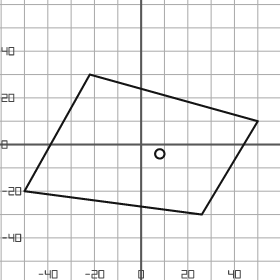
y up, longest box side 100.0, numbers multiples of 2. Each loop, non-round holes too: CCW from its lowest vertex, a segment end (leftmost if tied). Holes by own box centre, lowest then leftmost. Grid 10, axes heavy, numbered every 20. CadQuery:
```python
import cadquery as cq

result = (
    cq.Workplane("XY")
    .moveTo(26.0, -30.0)
    .lineTo(50.0, 10.0)
    .lineTo(-22.0, 30.0)
    .lineTo(-50.0, -20.0)
    .close()
    .moveTo(8.0, -4.0)
    .circle(2.0)
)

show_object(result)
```